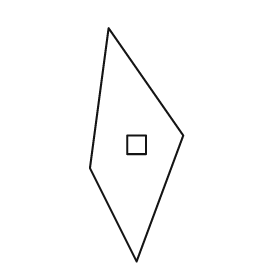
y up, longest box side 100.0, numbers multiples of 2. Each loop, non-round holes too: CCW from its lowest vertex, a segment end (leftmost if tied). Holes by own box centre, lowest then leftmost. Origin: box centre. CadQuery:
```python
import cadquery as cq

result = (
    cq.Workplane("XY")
    .moveTo(0.0, -50.0)
    .lineTo(20.0, 4.0)
    .lineTo(-12.0, 50.0)
    .lineTo(-20.0, -10.0)
    .close()
    .moveTo(-4.0, -4.0)
    .lineTo(4.0, -4.0)
    .lineTo(4.0, 4.0)
    .lineTo(-4.0, 4.0)
    .close()
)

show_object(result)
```